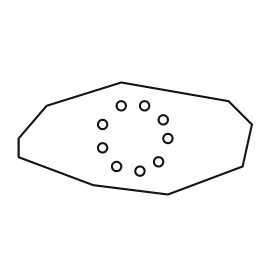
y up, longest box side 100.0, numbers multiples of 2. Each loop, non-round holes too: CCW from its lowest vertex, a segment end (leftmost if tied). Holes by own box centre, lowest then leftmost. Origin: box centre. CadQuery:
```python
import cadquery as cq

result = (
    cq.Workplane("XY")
    .moveTo(14.0, -24.0)
    .lineTo(46.0, -12.0)
    .lineTo(50.0, 6.0)
    .lineTo(40.0, 16.0)
    .lineTo(-6.0, 24.0)
    .lineTo(-38.0, 14.0)
    .lineTo(-50.0, 0.0)
    .lineTo(-50.0, -8.0)
    .lineTo(-18.0, -20.0)
    .close()
    .moveTo(2.0, -14.0)
    .circle(2.0)
    .moveTo(-8.0, -12.0)
    .circle(2.0)
    .moveTo(10.0, -10.0)
    .circle(2.0)
    .moveTo(-14.0, -4.0)
    .circle(2.0)
    .moveTo(14.0, 0.0)
    .circle(2.0)
    .moveTo(-14.0, 6.0)
    .circle(2.0)
    .moveTo(12.0, 8.0)
    .circle(2.0)
    .moveTo(-6.0, 14.0)
    .circle(2.0)
    .moveTo(4.0, 14.0)
    .circle(2.0)
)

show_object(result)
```